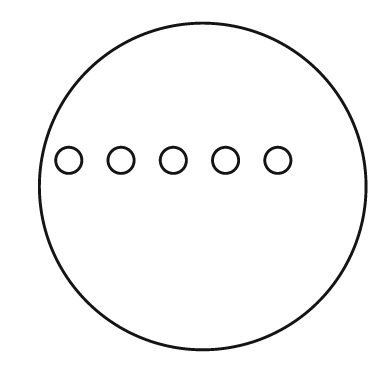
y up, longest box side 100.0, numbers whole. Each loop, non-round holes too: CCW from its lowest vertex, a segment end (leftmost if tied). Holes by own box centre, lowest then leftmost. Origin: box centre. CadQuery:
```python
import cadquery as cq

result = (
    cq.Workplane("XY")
    .moveTo(0.0, 0.0)
    .circle(50.0)
    .moveTo(-41.0, 8.0)
    .circle(4.0)
    .moveTo(-25.0, 8.0)
    .circle(4.0)
    .moveTo(-9.0, 8.0)
    .circle(4.0)
    .moveTo(7.0, 8.0)
    .circle(4.0)
    .moveTo(23.0, 8.0)
    .circle(4.0)
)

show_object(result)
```